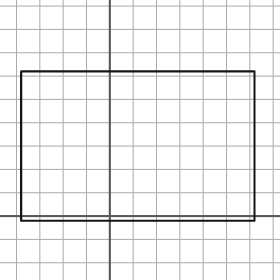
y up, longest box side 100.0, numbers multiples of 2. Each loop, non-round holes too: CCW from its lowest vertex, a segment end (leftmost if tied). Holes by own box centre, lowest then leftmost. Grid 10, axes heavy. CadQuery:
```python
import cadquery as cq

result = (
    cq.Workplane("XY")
    .moveTo(-38.0, -2.0)
    .lineTo(62.0, -2.0)
    .lineTo(62.0, 62.0)
    .lineTo(-38.0, 62.0)
    .close()
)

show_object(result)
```